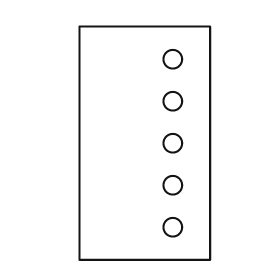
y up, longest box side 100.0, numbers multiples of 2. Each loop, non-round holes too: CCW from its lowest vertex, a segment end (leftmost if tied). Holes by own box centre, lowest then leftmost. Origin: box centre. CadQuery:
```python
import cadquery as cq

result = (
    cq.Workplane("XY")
    .moveTo(-28.0, -50.0)
    .lineTo(28.0, -50.0)
    .lineTo(28.0, 50.0)
    .lineTo(-28.0, 50.0)
    .close()
    .moveTo(12.0, -36.0)
    .circle(4.0)
    .moveTo(12.0, -18.0)
    .circle(4.0)
    .moveTo(12.0, 0.0)
    .circle(4.0)
    .moveTo(12.0, 18.0)
    .circle(4.0)
    .moveTo(12.0, 36.0)
    .circle(4.0)
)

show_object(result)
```